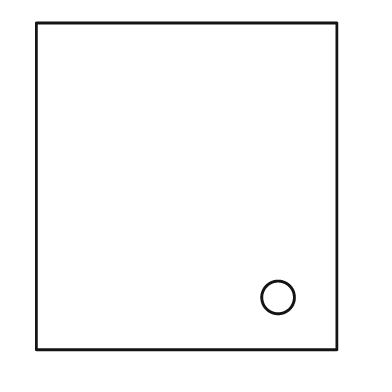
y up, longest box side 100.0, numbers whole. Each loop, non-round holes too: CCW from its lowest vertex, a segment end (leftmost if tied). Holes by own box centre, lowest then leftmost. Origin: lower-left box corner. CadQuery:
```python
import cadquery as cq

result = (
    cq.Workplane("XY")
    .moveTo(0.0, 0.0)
    .lineTo(92.0, 0.0)
    .lineTo(92.0, 100.0)
    .lineTo(0.0, 100.0)
    .close()
    .moveTo(74.0, 16.0)
    .circle(5.0)
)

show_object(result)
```